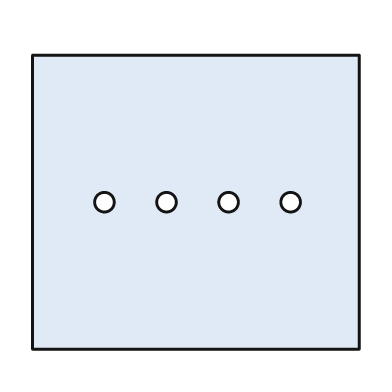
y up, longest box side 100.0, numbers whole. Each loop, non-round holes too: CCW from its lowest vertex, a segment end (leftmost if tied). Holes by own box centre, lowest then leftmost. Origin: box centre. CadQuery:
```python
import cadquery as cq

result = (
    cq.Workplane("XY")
    .moveTo(-50.0, -45.0)
    .lineTo(50.0, -45.0)
    .lineTo(50.0, 45.0)
    .lineTo(-50.0, 45.0)
    .close()
    .moveTo(-28.0, 0.0)
    .circle(3.0)
    .moveTo(-9.0, 0.0)
    .circle(3.0)
    .moveTo(10.0, 0.0)
    .circle(3.0)
    .moveTo(29.0, 0.0)
    .circle(3.0)
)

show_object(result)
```